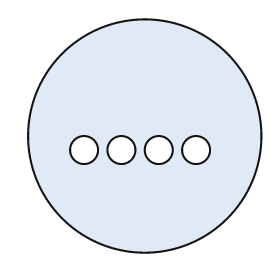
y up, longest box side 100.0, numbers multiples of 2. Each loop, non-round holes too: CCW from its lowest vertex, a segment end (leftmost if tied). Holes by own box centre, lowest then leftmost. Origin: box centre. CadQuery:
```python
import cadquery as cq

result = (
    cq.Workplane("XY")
    .moveTo(0.0, 0.0)
    .circle(50.0)
    .moveTo(-26.0, -6.0)
    .circle(6.0)
    .moveTo(-10.0, -6.0)
    .circle(6.0)
    .moveTo(6.0, -6.0)
    .circle(6.0)
    .moveTo(22.0, -6.0)
    .circle(6.0)
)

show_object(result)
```